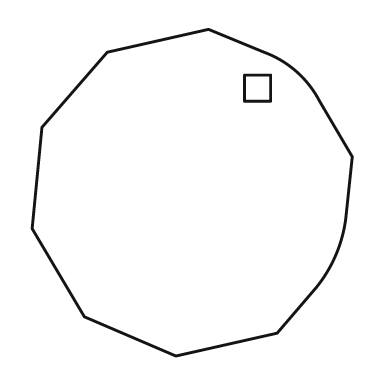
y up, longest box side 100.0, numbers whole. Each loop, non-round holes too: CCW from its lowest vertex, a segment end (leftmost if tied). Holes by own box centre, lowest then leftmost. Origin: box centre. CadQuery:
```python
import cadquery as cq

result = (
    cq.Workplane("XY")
    .moveTo(-5.0, -50.0)
    .lineTo(26.0, -43.0)
    .lineTo(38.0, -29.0)
    .threePointArc((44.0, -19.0), (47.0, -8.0))
    .lineTo(49.0, 11.0)
    .lineTo(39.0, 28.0)
    .threePointArc((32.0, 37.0), (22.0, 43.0))
    .lineTo(5.0, 50.0)
    .lineTo(-26.0, 43.0)
    .lineTo(-46.0, 20.0)
    .lineTo(-49.0, -11.0)
    .lineTo(-33.0, -38.0)
    .close()
    .moveTo(16.0, 28.0)
    .lineTo(24.0, 28.0)
    .lineTo(24.0, 36.0)
    .lineTo(16.0, 36.0)
    .close()
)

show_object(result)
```